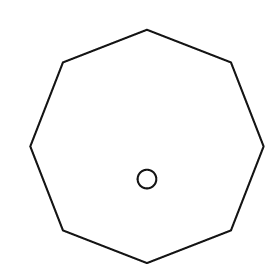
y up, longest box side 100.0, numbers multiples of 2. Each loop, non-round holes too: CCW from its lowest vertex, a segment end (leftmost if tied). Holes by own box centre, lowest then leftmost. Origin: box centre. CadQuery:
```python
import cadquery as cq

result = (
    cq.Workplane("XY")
    .moveTo(0.0, -50.0)
    .lineTo(36.0, -36.0)
    .lineTo(50.0, 0.0)
    .lineTo(36.0, 36.0)
    .lineTo(0.0, 50.0)
    .lineTo(-36.0, 36.0)
    .lineTo(-50.0, 0.0)
    .lineTo(-36.0, -36.0)
    .close()
    .moveTo(0.0, -14.0)
    .circle(4.0)
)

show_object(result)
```